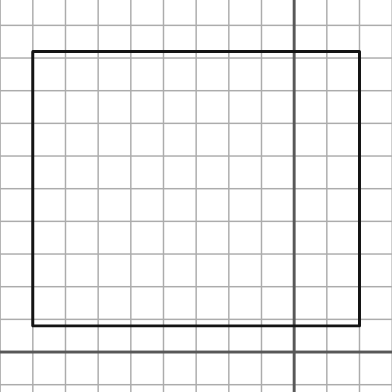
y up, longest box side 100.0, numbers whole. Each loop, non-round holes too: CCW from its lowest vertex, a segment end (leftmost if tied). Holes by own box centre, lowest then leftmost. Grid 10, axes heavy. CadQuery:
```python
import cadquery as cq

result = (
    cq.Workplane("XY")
    .moveTo(-80.0, 8.0)
    .lineTo(20.0, 8.0)
    .lineTo(20.0, 92.0)
    .lineTo(-80.0, 92.0)
    .close()
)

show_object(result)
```